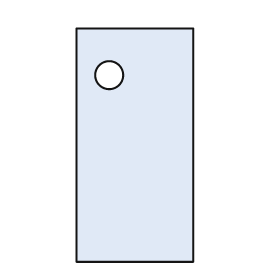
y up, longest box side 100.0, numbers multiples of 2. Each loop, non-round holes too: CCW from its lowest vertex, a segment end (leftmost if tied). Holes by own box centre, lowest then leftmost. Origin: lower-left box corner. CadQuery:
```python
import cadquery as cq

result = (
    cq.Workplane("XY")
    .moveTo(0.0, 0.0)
    .lineTo(50.0, 0.0)
    .lineTo(50.0, 100.0)
    .lineTo(0.0, 100.0)
    .close()
    .moveTo(14.0, 80.0)
    .circle(6.0)
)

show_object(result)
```